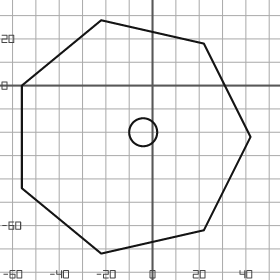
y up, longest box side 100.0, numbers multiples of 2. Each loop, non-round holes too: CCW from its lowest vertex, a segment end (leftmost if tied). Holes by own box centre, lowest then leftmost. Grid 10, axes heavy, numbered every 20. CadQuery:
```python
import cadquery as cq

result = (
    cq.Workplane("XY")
    .moveTo(-22.0, -72.0)
    .lineTo(22.0, -62.0)
    .lineTo(42.0, -22.0)
    .lineTo(22.0, 18.0)
    .lineTo(-22.0, 28.0)
    .lineTo(-56.0, 0.0)
    .lineTo(-56.0, -44.0)
    .close()
    .moveTo(-4.0, -20.0)
    .circle(6.0)
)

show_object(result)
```